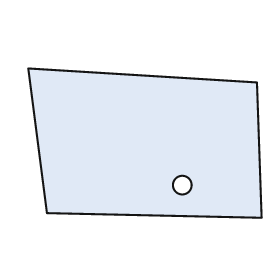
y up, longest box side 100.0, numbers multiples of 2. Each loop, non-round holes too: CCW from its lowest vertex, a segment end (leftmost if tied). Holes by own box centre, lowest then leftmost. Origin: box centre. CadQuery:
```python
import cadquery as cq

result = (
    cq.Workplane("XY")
    .moveTo(50.0, -32.0)
    .lineTo(48.0, 26.0)
    .lineTo(-50.0, 32.0)
    .lineTo(-42.0, -30.0)
    .close()
    .moveTo(16.0, -18.0)
    .circle(4.0)
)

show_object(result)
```